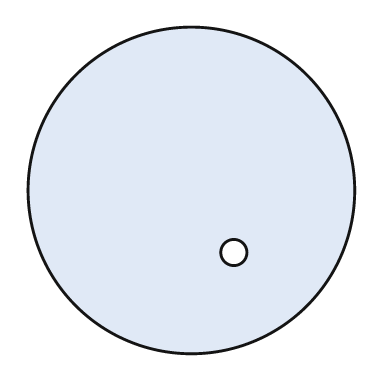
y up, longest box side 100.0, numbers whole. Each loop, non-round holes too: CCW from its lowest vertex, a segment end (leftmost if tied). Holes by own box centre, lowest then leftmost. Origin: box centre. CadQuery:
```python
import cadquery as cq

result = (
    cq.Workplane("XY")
    .moveTo(0.0, 0.0)
    .circle(50.0)
    .moveTo(13.0, -19.0)
    .circle(4.0)
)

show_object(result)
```